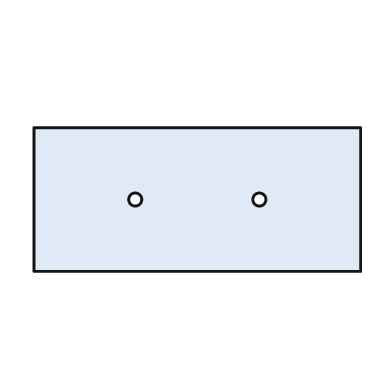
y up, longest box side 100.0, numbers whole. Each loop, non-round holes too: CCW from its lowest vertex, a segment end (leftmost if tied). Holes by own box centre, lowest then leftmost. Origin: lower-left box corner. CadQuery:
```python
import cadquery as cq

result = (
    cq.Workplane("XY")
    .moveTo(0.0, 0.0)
    .lineTo(100.0, 0.0)
    .lineTo(100.0, 44.0)
    .lineTo(0.0, 44.0)
    .close()
    .moveTo(31.0, 22.0)
    .circle(2.0)
    .moveTo(69.0, 22.0)
    .circle(2.0)
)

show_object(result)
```